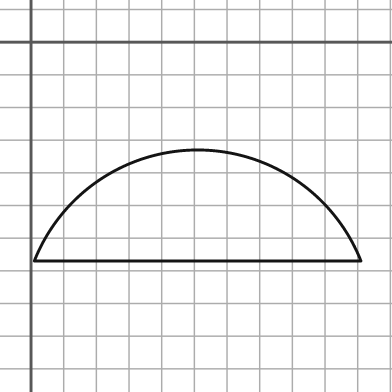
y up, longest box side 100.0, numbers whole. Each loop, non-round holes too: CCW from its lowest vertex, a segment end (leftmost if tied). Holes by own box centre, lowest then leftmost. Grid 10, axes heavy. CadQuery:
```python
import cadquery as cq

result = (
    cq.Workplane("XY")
    .moveTo(1.0, -67.0)
    .lineTo(101.0, -67.0)
    .threePointArc((51.0, -33.0), (1.0, -67.0))
    .close()
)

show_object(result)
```